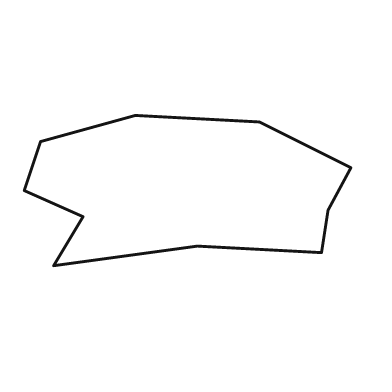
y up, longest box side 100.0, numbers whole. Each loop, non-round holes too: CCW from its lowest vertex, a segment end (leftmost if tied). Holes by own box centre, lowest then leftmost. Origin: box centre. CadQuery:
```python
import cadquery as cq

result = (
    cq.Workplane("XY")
    .moveTo(-41.0, -23.0)
    .lineTo(3.0, -17.0)
    .lineTo(41.0, -19.0)
    .lineTo(43.0, -6.0)
    .lineTo(50.0, 7.0)
    .lineTo(22.0, 21.0)
    .lineTo(-16.0, 23.0)
    .lineTo(-45.0, 15.0)
    .lineTo(-50.0, 0.0)
    .lineTo(-32.0, -8.0)
    .close()
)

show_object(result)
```